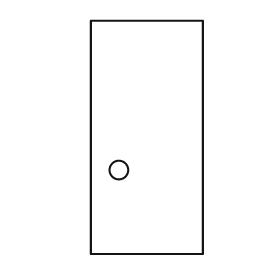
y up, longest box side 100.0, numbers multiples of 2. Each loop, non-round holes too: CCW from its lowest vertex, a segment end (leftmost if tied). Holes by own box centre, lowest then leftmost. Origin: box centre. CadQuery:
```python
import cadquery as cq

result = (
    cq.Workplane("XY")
    .moveTo(-24.0, -50.0)
    .lineTo(24.0, -50.0)
    .lineTo(24.0, 50.0)
    .lineTo(-24.0, 50.0)
    .close()
    .moveTo(-12.0, -14.0)
    .circle(4.0)
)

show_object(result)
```